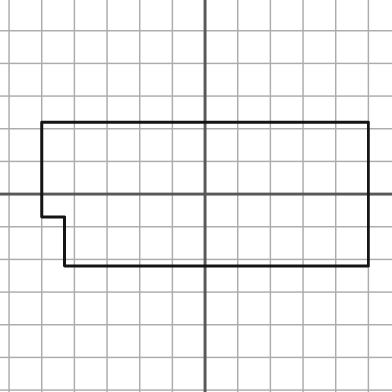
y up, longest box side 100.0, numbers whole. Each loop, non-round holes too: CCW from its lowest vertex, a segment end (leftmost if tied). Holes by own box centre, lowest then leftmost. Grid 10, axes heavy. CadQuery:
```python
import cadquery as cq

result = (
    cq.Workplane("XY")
    .moveTo(-43.0, -22.0)
    .lineTo(50.0, -22.0)
    .lineTo(50.0, 22.0)
    .lineTo(-50.0, 22.0)
    .lineTo(-50.0, -7.0)
    .lineTo(-43.0, -7.0)
    .close()
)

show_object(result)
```